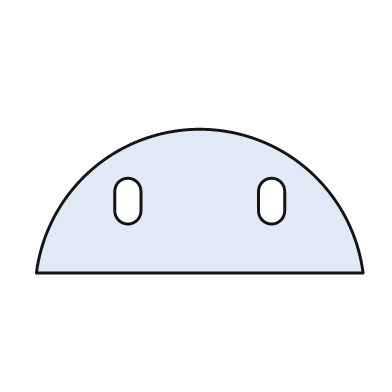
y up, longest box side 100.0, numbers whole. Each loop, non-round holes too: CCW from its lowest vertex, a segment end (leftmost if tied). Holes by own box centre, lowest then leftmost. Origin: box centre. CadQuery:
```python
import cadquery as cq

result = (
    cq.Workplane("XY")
    .moveTo(-50.0, -22.0)
    .lineTo(50.0, -22.0)
    .threePointArc((0.0, 22.0), (-50.0, -22.0))
    .close()
    .moveTo(-26.0, -3.0)
    .threePointArc((-22.0, -7.0), (-18.0, -3.0))
    .lineTo(-18.0, 3.0)
    .threePointArc((-22.0, 7.0), (-26.0, 3.0))
    .close()
    .moveTo(18.0, -3.0)
    .threePointArc((22.0, -7.0), (26.0, -3.0))
    .lineTo(26.0, 3.0)
    .threePointArc((22.0, 7.0), (18.0, 3.0))
    .close()
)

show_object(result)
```